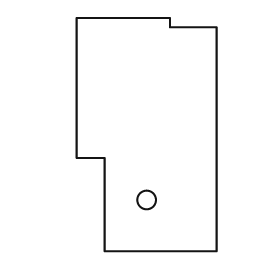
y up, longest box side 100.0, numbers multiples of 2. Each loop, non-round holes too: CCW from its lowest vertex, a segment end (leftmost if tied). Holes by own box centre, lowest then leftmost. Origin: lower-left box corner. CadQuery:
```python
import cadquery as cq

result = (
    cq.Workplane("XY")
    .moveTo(12.0, 0.0)
    .lineTo(60.0, 0.0)
    .lineTo(60.0, 96.0)
    .lineTo(40.0, 96.0)
    .lineTo(40.0, 100.0)
    .lineTo(0.0, 100.0)
    .lineTo(0.0, 40.0)
    .lineTo(12.0, 40.0)
    .close()
    .moveTo(30.0, 22.0)
    .circle(4.0)
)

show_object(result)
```